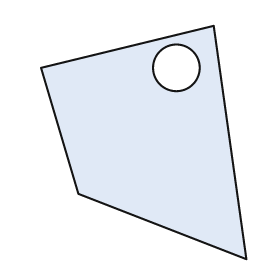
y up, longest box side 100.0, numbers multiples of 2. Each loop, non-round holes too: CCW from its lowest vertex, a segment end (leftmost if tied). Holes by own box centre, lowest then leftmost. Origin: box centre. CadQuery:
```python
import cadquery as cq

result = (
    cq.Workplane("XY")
    .moveTo(44.0, -50.0)
    .lineTo(30.0, 50.0)
    .lineTo(-44.0, 32.0)
    .lineTo(-28.0, -22.0)
    .close()
    .moveTo(14.0, 32.0)
    .circle(10.0)
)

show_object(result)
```